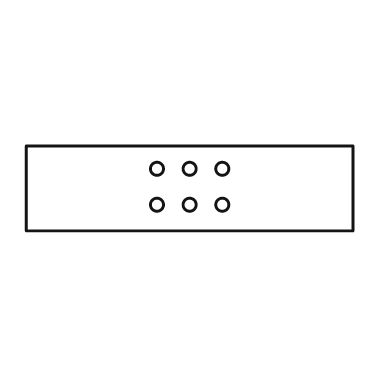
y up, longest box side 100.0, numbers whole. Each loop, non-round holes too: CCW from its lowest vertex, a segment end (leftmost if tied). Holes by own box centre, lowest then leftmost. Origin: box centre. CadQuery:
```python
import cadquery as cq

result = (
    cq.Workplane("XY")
    .moveTo(-50.0, -13.0)
    .lineTo(50.0, -13.0)
    .lineTo(50.0, 13.0)
    .lineTo(-50.0, 13.0)
    .close()
    .moveTo(-10.0, -5.0)
    .circle(2.0)
    .moveTo(0.0, -5.0)
    .circle(2.0)
    .moveTo(10.0, -5.0)
    .circle(2.0)
    .moveTo(-10.0, 6.0)
    .circle(2.0)
    .moveTo(0.0, 6.0)
    .circle(2.0)
    .moveTo(10.0, 6.0)
    .circle(2.0)
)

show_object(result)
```